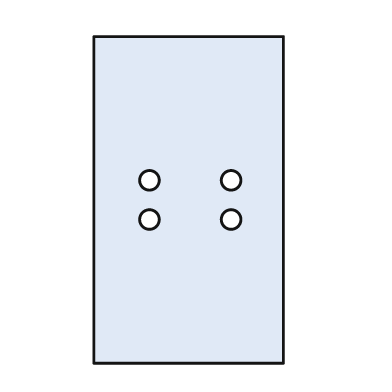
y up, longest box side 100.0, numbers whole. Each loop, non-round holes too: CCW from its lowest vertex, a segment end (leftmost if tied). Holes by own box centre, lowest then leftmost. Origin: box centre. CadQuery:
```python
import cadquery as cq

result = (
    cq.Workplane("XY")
    .moveTo(-29.0, -50.0)
    .lineTo(29.0, -50.0)
    .lineTo(29.0, 50.0)
    .lineTo(-29.0, 50.0)
    .close()
    .moveTo(-12.0, -6.0)
    .circle(3.0)
    .moveTo(13.0, -6.0)
    .circle(3.0)
    .moveTo(-12.0, 6.0)
    .circle(3.0)
    .moveTo(13.0, 6.0)
    .circle(3.0)
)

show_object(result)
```